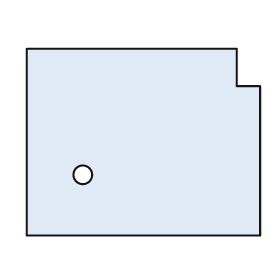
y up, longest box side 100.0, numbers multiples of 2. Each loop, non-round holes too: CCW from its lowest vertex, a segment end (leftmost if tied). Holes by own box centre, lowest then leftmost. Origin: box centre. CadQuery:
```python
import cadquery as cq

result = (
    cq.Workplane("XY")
    .moveTo(-50.0, -40.0)
    .lineTo(50.0, -40.0)
    .lineTo(50.0, 24.0)
    .lineTo(40.0, 24.0)
    .lineTo(40.0, 40.0)
    .lineTo(-50.0, 40.0)
    .close()
    .moveTo(-26.0, -14.0)
    .circle(4.0)
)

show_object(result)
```